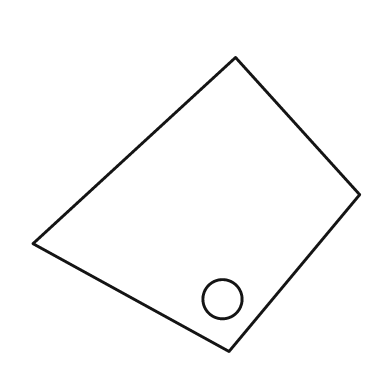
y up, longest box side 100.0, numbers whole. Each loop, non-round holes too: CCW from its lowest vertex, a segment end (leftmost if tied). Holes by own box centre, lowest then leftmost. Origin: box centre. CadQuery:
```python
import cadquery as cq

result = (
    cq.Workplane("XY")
    .moveTo(10.0, -45.0)
    .lineTo(50.0, 3.0)
    .lineTo(12.0, 45.0)
    .lineTo(-50.0, -12.0)
    .close()
    .moveTo(8.0, -29.0)
    .circle(6.0)
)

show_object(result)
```